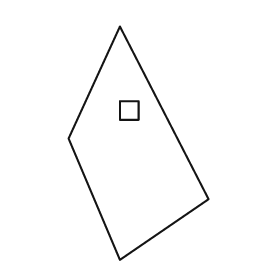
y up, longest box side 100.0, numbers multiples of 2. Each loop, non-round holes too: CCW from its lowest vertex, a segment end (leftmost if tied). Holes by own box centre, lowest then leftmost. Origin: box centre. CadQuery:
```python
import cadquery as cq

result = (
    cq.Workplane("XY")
    .moveTo(-8.0, -50.0)
    .lineTo(30.0, -24.0)
    .lineTo(-8.0, 50.0)
    .lineTo(-30.0, 2.0)
    .close()
    .moveTo(-8.0, 10.0)
    .lineTo(0.0, 10.0)
    .lineTo(0.0, 18.0)
    .lineTo(-8.0, 18.0)
    .close()
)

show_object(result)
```